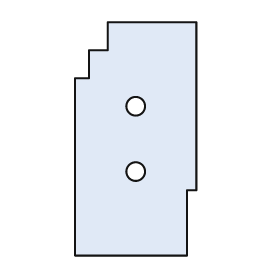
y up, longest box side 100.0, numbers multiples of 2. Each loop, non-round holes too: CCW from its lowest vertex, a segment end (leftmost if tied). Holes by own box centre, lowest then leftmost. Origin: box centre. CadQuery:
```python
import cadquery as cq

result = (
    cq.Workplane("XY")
    .moveTo(-26.0, -50.0)
    .lineTo(22.0, -50.0)
    .lineTo(22.0, -22.0)
    .lineTo(26.0, -22.0)
    .lineTo(26.0, 50.0)
    .lineTo(-12.0, 50.0)
    .lineTo(-12.0, 38.0)
    .lineTo(-20.0, 38.0)
    .lineTo(-20.0, 26.0)
    .lineTo(-26.0, 26.0)
    .close()
    .moveTo(0.0, -14.0)
    .circle(4.0)
    .moveTo(0.0, 14.0)
    .circle(4.0)
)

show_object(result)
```